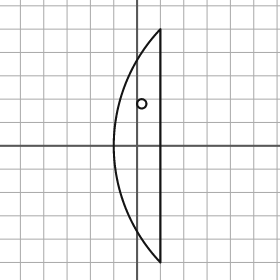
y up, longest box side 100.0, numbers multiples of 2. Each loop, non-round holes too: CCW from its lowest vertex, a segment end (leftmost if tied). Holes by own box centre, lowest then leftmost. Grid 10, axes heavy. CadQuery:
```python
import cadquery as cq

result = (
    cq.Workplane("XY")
    .moveTo(10.0, -50.0)
    .lineTo(10.0, 50.0)
    .threePointArc((-10.0, 0.0), (10.0, -50.0))
    .close()
    .moveTo(2.0, 18.0)
    .circle(2.0)
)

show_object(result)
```